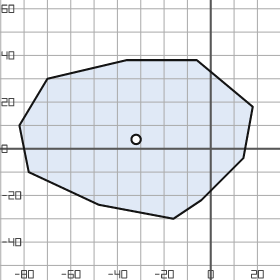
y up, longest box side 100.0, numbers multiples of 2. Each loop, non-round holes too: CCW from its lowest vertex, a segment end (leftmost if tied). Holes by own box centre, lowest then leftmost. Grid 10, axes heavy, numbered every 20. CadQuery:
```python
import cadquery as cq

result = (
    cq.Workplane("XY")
    .moveTo(-16.0, -30.0)
    .lineTo(-4.0, -22.0)
    .lineTo(14.0, -4.0)
    .lineTo(18.0, 18.0)
    .lineTo(-6.0, 38.0)
    .lineTo(-36.0, 38.0)
    .lineTo(-70.0, 30.0)
    .lineTo(-82.0, 10.0)
    .lineTo(-78.0, -10.0)
    .lineTo(-48.0, -24.0)
    .close()
    .moveTo(-32.0, 4.0)
    .circle(2.0)
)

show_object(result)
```